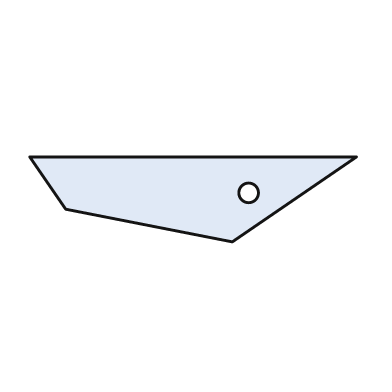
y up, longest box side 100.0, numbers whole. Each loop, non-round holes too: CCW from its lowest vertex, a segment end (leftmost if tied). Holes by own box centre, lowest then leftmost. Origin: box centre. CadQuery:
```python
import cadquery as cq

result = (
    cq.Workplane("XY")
    .moveTo(12.0, -13.0)
    .lineTo(50.0, 13.0)
    .lineTo(-50.0, 13.0)
    .lineTo(-39.0, -3.0)
    .close()
    .moveTo(17.0, 2.0)
    .circle(3.0)
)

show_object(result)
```